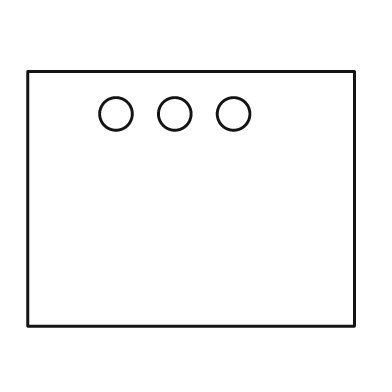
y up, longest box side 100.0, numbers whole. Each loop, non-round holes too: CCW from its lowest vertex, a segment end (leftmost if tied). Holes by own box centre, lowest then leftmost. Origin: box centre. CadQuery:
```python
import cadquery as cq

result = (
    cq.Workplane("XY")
    .moveTo(-50.0, -39.0)
    .lineTo(50.0, -39.0)
    .lineTo(50.0, 39.0)
    .lineTo(-50.0, 39.0)
    .close()
    .moveTo(-23.0, 26.0)
    .circle(5.0)
    .moveTo(-5.0, 26.0)
    .circle(5.0)
    .moveTo(13.0, 26.0)
    .circle(5.0)
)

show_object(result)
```